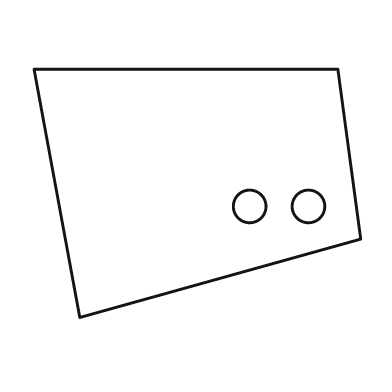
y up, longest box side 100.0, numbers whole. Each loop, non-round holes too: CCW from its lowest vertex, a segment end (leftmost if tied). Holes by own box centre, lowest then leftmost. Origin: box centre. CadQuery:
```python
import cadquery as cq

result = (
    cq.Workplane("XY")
    .moveTo(-36.0, -38.0)
    .lineTo(50.0, -14.0)
    .lineTo(43.0, 38.0)
    .lineTo(-50.0, 38.0)
    .close()
    .moveTo(16.0, -4.0)
    .circle(5.0)
    .moveTo(34.0, -4.0)
    .circle(5.0)
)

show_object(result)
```